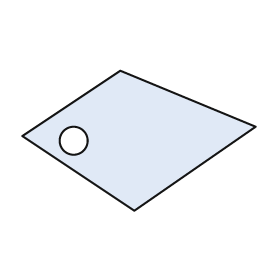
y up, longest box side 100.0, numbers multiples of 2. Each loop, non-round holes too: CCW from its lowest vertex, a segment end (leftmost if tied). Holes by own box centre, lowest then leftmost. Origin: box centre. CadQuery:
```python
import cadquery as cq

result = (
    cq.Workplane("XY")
    .moveTo(-2.0, -30.0)
    .lineTo(50.0, 6.0)
    .lineTo(-8.0, 30.0)
    .lineTo(-50.0, 2.0)
    .close()
    .moveTo(-28.0, 0.0)
    .circle(6.0)
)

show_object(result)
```